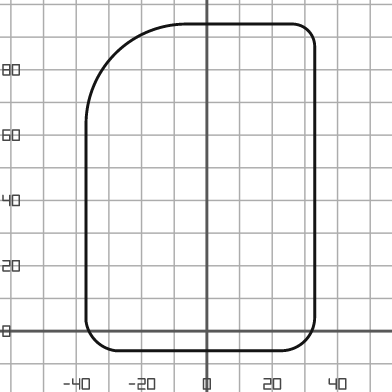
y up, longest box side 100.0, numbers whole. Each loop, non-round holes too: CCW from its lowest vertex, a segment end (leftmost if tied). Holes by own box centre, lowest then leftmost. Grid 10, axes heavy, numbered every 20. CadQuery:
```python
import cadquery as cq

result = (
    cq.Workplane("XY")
    .moveTo(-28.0, -6.0)
    .lineTo(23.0, -6.0)
    .threePointArc((30.0, -3.0), (33.0, 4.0))
    .lineTo(33.0, 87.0)
    .threePointArc((31.0, 92.0), (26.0, 94.0))
    .lineTo(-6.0, 94.0)
    .threePointArc((-28.0, 85.0), (-37.0, 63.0))
    .lineTo(-37.0, 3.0)
    .threePointArc((-34.0, -3.0), (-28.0, -6.0))
    .close()
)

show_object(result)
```